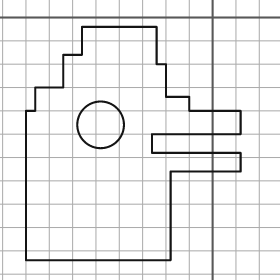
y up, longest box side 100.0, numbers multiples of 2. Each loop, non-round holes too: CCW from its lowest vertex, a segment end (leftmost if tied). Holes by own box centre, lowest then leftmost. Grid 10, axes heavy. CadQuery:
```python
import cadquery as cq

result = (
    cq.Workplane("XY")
    .moveTo(-80.0, -104.0)
    .lineTo(-18.0, -104.0)
    .lineTo(-18.0, -66.0)
    .lineTo(12.0, -66.0)
    .lineTo(12.0, -58.0)
    .lineTo(-26.0, -58.0)
    .lineTo(-26.0, -50.0)
    .lineTo(12.0, -50.0)
    .lineTo(12.0, -40.0)
    .lineTo(-10.0, -40.0)
    .lineTo(-10.0, -34.0)
    .lineTo(-20.0, -34.0)
    .lineTo(-20.0, -20.0)
    .lineTo(-24.0, -20.0)
    .lineTo(-24.0, -4.0)
    .lineTo(-56.0, -4.0)
    .lineTo(-56.0, -16.0)
    .lineTo(-64.0, -16.0)
    .lineTo(-64.0, -30.0)
    .lineTo(-76.0, -30.0)
    .lineTo(-76.0, -40.0)
    .lineTo(-80.0, -40.0)
    .close()
    .moveTo(-48.0, -46.0)
    .circle(10.0)
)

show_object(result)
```